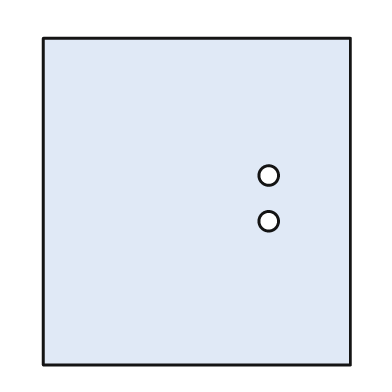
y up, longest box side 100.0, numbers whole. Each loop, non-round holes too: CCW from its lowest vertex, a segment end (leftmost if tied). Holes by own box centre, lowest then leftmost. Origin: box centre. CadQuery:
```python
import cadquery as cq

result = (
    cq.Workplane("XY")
    .moveTo(-47.0, -50.0)
    .lineTo(47.0, -50.0)
    .lineTo(47.0, 50.0)
    .lineTo(-47.0, 50.0)
    .close()
    .moveTo(22.0, -6.0)
    .circle(3.0)
    .moveTo(22.0, 8.0)
    .circle(3.0)
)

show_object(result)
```